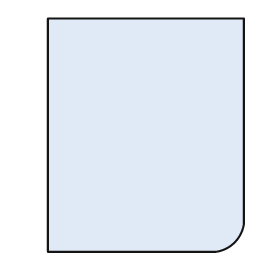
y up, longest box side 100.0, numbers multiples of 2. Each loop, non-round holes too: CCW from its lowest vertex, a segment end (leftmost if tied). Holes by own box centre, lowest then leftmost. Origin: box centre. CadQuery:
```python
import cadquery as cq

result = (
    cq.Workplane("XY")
    .moveTo(-42.0, -50.0)
    .lineTo(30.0, -50.0)
    .threePointArc((38.0, -46.0), (42.0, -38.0))
    .lineTo(42.0, 50.0)
    .lineTo(-42.0, 50.0)
    .close()
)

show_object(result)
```